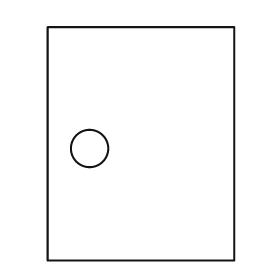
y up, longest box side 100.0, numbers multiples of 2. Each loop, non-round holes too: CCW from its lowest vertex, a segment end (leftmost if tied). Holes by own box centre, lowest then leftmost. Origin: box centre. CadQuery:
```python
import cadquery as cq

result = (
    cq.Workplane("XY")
    .moveTo(-40.0, -50.0)
    .lineTo(40.0, -50.0)
    .lineTo(40.0, 50.0)
    .lineTo(-40.0, 50.0)
    .close()
    .moveTo(-22.0, -2.0)
    .circle(8.0)
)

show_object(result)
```